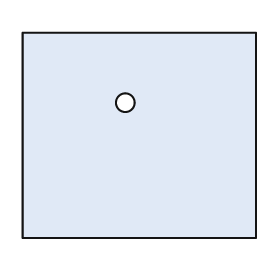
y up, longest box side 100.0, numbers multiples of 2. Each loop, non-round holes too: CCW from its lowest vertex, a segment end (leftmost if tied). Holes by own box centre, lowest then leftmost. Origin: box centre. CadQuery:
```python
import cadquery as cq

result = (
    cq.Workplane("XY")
    .moveTo(-50.0, -44.0)
    .lineTo(50.0, -44.0)
    .lineTo(50.0, 44.0)
    .lineTo(-50.0, 44.0)
    .close()
    .moveTo(-6.0, 14.0)
    .circle(4.0)
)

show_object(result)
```